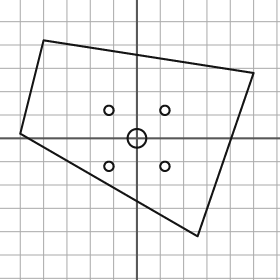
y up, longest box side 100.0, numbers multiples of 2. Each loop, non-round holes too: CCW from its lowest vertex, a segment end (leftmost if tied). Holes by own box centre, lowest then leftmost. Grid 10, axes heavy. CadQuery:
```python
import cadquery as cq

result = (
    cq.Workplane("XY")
    .moveTo(26.0, -42.0)
    .lineTo(50.0, 28.0)
    .lineTo(-40.0, 42.0)
    .lineTo(-50.0, 2.0)
    .close()
    .moveTo(-12.0, -12.0)
    .circle(2.0)
    .moveTo(12.0, -12.0)
    .circle(2.0)
    .moveTo(0.0, 0.0)
    .circle(4.0)
    .moveTo(-12.0, 12.0)
    .circle(2.0)
    .moveTo(12.0, 12.0)
    .circle(2.0)
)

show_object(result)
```